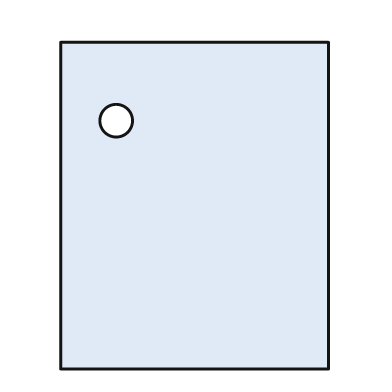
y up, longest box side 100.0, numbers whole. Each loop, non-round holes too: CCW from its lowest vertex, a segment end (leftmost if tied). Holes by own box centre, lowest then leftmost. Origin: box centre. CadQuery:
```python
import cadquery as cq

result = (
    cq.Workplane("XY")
    .moveTo(-41.0, -50.0)
    .lineTo(41.0, -50.0)
    .lineTo(41.0, 50.0)
    .lineTo(-41.0, 50.0)
    .close()
    .moveTo(-24.0, 26.0)
    .circle(5.0)
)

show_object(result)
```